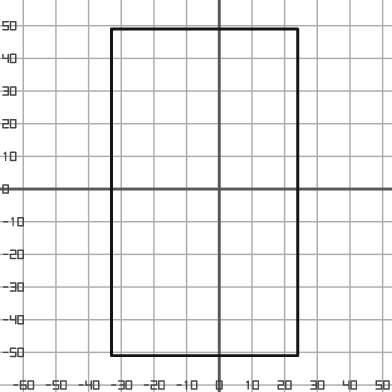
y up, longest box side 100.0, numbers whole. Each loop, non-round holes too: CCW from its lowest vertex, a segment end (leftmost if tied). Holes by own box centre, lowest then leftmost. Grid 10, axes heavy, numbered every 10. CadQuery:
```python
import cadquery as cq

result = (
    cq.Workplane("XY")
    .moveTo(-33.0, -51.0)
    .lineTo(24.0, -51.0)
    .lineTo(24.0, 49.0)
    .lineTo(-33.0, 49.0)
    .close()
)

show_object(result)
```